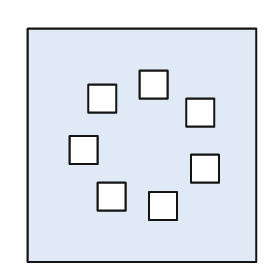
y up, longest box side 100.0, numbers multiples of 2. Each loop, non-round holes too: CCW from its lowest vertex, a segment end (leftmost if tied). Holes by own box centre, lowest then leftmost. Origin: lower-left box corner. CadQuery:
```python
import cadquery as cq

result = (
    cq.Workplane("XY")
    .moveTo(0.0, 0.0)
    .lineTo(98.0, 0.0)
    .lineTo(98.0, 100.0)
    .lineTo(0.0, 100.0)
    .close()
    .moveTo(52.0, 18.0)
    .lineTo(64.0, 18.0)
    .lineTo(64.0, 30.0)
    .lineTo(52.0, 30.0)
    .close()
    .moveTo(30.0, 22.0)
    .lineTo(42.0, 22.0)
    .lineTo(42.0, 34.0)
    .lineTo(30.0, 34.0)
    .close()
    .moveTo(70.0, 34.0)
    .lineTo(82.0, 34.0)
    .lineTo(82.0, 46.0)
    .lineTo(70.0, 46.0)
    .close()
    .moveTo(18.0, 42.0)
    .lineTo(30.0, 42.0)
    .lineTo(30.0, 54.0)
    .lineTo(18.0, 54.0)
    .close()
    .moveTo(68.0, 58.0)
    .lineTo(80.0, 58.0)
    .lineTo(80.0, 70.0)
    .lineTo(68.0, 70.0)
    .close()
    .moveTo(26.0, 64.0)
    .lineTo(38.0, 64.0)
    .lineTo(38.0, 76.0)
    .lineTo(26.0, 76.0)
    .close()
    .moveTo(48.0, 70.0)
    .lineTo(60.0, 70.0)
    .lineTo(60.0, 82.0)
    .lineTo(48.0, 82.0)
    .close()
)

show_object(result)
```